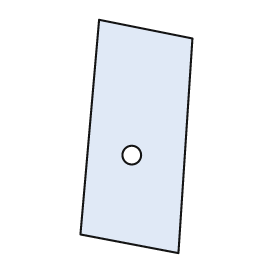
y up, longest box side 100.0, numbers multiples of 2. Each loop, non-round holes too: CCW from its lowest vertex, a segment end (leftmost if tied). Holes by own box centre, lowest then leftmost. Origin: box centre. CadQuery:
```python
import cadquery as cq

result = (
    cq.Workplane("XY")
    .moveTo(18.0, -50.0)
    .lineTo(24.0, 42.0)
    .lineTo(-16.0, 50.0)
    .lineTo(-24.0, -42.0)
    .close()
    .moveTo(-2.0, -8.0)
    .circle(4.0)
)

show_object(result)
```